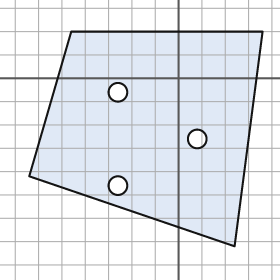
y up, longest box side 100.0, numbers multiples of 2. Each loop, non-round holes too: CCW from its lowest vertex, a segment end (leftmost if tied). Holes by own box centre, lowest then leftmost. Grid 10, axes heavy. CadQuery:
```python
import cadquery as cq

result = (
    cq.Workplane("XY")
    .moveTo(24.0, -72.0)
    .lineTo(36.0, 20.0)
    .lineTo(-46.0, 20.0)
    .lineTo(-64.0, -42.0)
    .close()
    .moveTo(-26.0, -46.0)
    .circle(4.0)
    .moveTo(8.0, -26.0)
    .circle(4.0)
    .moveTo(-26.0, -6.0)
    .circle(4.0)
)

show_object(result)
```